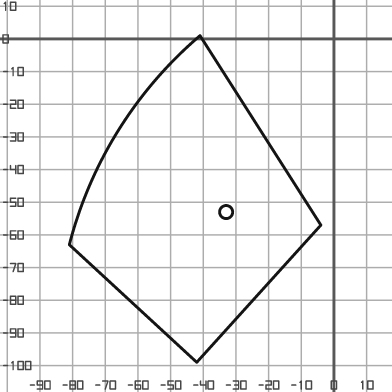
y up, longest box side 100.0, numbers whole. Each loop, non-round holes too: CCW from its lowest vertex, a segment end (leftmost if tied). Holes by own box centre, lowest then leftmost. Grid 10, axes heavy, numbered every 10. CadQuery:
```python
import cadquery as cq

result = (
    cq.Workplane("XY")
    .moveTo(-42.0, -99.0)
    .lineTo(-4.0, -57.0)
    .lineTo(-41.0, 1.0)
    .threePointArc((-66.0, -28.0), (-81.0, -63.0))
    .close()
    .moveTo(-33.0, -53.0)
    .circle(2.0)
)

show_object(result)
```